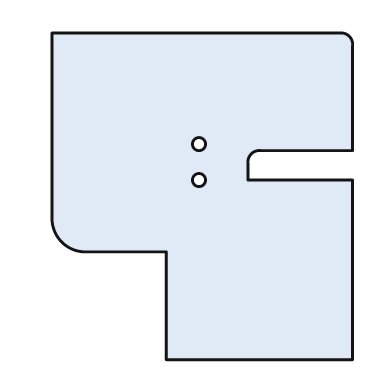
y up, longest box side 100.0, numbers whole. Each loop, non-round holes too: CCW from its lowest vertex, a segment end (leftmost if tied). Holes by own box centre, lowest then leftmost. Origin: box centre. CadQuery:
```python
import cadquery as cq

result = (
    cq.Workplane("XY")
    .moveTo(-11.0, -50.0)
    .lineTo(46.0, -50.0)
    .lineTo(46.0, 5.0)
    .lineTo(14.0, 5.0)
    .lineTo(14.0, 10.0)
    .threePointArc((15.0, 13.0), (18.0, 14.0))
    .lineTo(46.0, 14.0)
    .lineTo(46.0, 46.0)
    .threePointArc((45.0, 49.0), (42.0, 50.0))
    .lineTo(-46.0, 50.0)
    .lineTo(-46.0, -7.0)
    .threePointArc((-43.0, -14.0), (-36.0, -17.0))
    .lineTo(-11.0, -17.0)
    .close()
    .moveTo(-1.0, 5.0)
    .circle(2.0)
    .moveTo(-1.0, 16.0)
    .circle(2.0)
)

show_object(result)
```